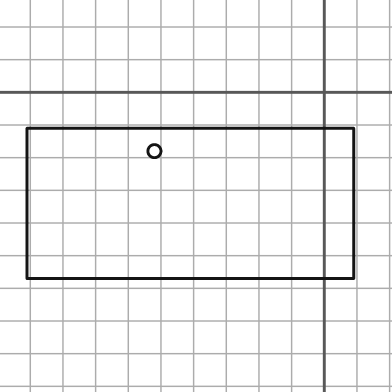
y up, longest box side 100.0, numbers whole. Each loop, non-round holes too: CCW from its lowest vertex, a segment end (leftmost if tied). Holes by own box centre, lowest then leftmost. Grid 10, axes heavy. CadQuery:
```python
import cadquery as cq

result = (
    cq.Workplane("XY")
    .moveTo(-91.0, -57.0)
    .lineTo(9.0, -57.0)
    .lineTo(9.0, -11.0)
    .lineTo(-91.0, -11.0)
    .close()
    .moveTo(-52.0, -18.0)
    .circle(2.0)
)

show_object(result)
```